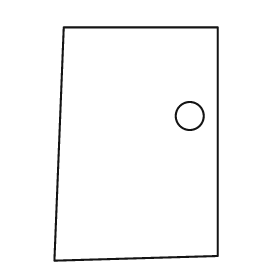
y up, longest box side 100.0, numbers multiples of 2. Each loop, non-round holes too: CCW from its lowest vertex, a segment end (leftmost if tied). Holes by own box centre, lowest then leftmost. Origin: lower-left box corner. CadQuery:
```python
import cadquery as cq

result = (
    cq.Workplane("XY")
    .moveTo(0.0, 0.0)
    .lineTo(70.0, 2.0)
    .lineTo(70.0, 100.0)
    .lineTo(4.0, 100.0)
    .close()
    .moveTo(58.0, 62.0)
    .circle(6.0)
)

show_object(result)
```